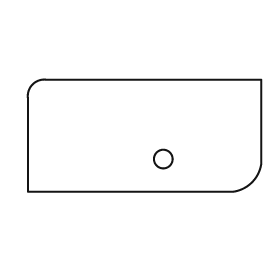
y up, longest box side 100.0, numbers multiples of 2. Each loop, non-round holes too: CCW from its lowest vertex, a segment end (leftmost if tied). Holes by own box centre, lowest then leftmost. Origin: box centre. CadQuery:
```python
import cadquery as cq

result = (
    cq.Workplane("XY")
    .moveTo(-50.0, -24.0)
    .lineTo(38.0, -24.0)
    .threePointArc((46.0, -20.0), (50.0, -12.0))
    .lineTo(50.0, 24.0)
    .lineTo(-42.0, 24.0)
    .threePointArc((-48.0, 22.0), (-50.0, 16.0))
    .close()
    .moveTo(8.0, -10.0)
    .circle(4.0)
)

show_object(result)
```